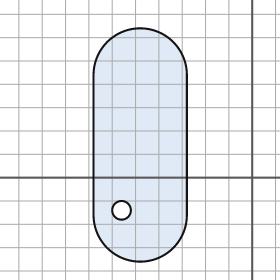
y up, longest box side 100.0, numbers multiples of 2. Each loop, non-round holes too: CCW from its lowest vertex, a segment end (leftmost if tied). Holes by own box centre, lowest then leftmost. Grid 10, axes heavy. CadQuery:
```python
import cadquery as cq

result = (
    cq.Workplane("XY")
    .moveTo(-68.0, -16.0)
    .threePointArc((-48.0, -36.0), (-28.0, -16.0))
    .lineTo(-28.0, 44.0)
    .threePointArc((-48.0, 64.0), (-68.0, 44.0))
    .close()
    .moveTo(-56.0, -14.0)
    .circle(4.0)
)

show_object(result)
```